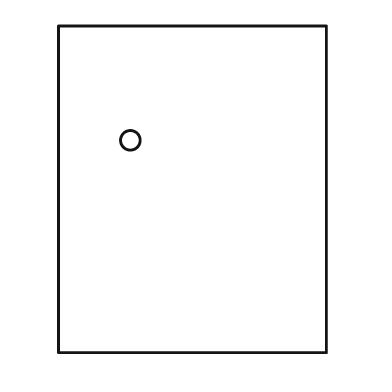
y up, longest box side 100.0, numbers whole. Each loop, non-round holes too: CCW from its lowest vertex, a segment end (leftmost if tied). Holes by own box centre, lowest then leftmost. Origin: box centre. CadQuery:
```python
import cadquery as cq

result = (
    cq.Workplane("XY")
    .moveTo(-41.0, -50.0)
    .lineTo(41.0, -50.0)
    .lineTo(41.0, 50.0)
    .lineTo(-41.0, 50.0)
    .close()
    .moveTo(-19.0, 15.0)
    .circle(3.0)
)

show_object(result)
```